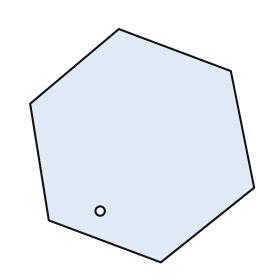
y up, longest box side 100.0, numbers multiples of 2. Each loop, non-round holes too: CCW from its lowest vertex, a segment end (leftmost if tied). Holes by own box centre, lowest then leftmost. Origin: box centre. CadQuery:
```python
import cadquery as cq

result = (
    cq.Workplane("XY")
    .moveTo(8.0, -50.0)
    .lineTo(48.0, -18.0)
    .lineTo(38.0, 32.0)
    .lineTo(-10.0, 50.0)
    .lineTo(-48.0, 18.0)
    .lineTo(-40.0, -32.0)
    .close()
    .moveTo(-18.0, -28.0)
    .circle(2.0)
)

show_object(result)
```